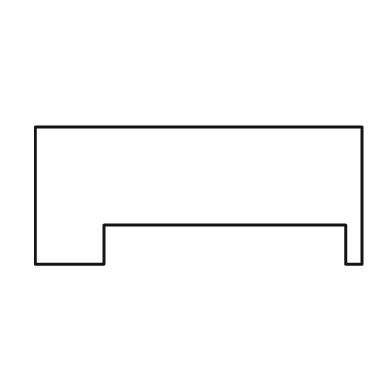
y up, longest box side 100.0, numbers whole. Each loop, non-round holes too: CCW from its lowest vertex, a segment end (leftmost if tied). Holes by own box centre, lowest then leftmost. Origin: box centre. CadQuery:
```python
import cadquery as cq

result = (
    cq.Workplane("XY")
    .moveTo(-50.0, -21.0)
    .lineTo(-29.0, -21.0)
    .lineTo(-29.0, -9.0)
    .lineTo(45.0, -9.0)
    .lineTo(45.0, -21.0)
    .lineTo(50.0, -21.0)
    .lineTo(50.0, 21.0)
    .lineTo(-50.0, 21.0)
    .close()
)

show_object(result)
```